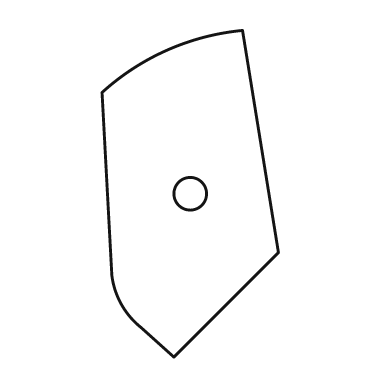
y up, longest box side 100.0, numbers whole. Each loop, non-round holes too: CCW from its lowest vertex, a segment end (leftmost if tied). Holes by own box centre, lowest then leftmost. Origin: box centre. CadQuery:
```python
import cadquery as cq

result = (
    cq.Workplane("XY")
    .moveTo(-5.0, -50.0)
    .lineTo(27.0, -18.0)
    .lineTo(16.0, 50.0)
    .threePointArc((-7.0, 44.0), (-27.0, 31.0))
    .lineTo(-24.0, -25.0)
    .threePointArc((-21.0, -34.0), (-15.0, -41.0))
    .close()
    .moveTo(0.0, 0.0)
    .circle(5.0)
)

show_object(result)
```